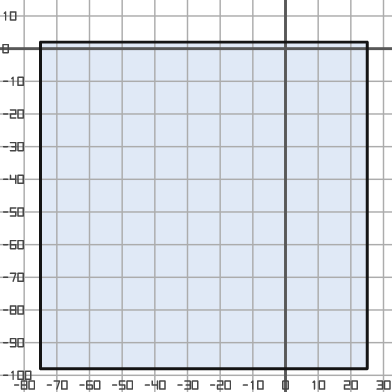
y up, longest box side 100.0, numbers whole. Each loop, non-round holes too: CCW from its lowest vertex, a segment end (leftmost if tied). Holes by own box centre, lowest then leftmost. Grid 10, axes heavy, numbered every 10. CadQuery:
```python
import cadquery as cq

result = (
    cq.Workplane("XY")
    .moveTo(-75.0, -98.0)
    .lineTo(25.0, -98.0)
    .lineTo(25.0, 2.0)
    .lineTo(-75.0, 2.0)
    .close()
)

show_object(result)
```